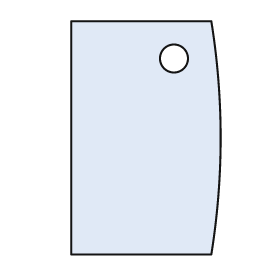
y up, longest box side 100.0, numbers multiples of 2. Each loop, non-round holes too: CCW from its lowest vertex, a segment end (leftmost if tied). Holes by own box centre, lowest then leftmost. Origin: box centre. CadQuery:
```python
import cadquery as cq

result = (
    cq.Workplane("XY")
    .moveTo(-32.0, -50.0)
    .lineTo(28.0, -50.0)
    .threePointArc((32.0, 0.0), (28.0, 50.0))
    .lineTo(-32.0, 50.0)
    .close()
    .moveTo(12.0, 34.0)
    .circle(6.0)
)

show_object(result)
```